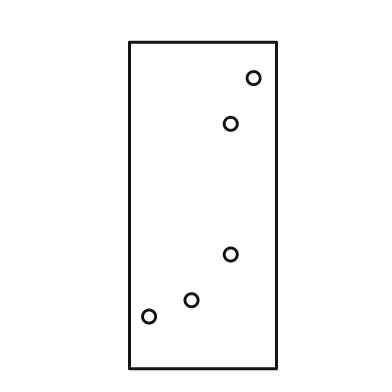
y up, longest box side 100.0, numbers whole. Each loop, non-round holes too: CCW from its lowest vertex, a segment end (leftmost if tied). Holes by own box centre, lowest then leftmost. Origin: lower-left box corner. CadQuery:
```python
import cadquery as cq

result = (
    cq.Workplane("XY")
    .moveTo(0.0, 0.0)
    .lineTo(45.0, 0.0)
    .lineTo(45.0, 100.0)
    .lineTo(0.0, 100.0)
    .close()
    .moveTo(6.0, 16.0)
    .circle(2.0)
    .moveTo(19.0, 21.0)
    .circle(2.0)
    .moveTo(31.0, 35.0)
    .circle(2.0)
    .moveTo(31.0, 75.0)
    .circle(2.0)
    .moveTo(38.0, 89.0)
    .circle(2.0)
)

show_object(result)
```